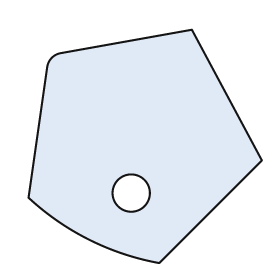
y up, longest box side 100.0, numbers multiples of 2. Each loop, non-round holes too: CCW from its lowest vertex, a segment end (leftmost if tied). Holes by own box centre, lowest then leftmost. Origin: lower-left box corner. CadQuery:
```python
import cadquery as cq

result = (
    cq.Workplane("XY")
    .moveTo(56.0, 0.0)
    .lineTo(100.0, 44.0)
    .lineTo(70.0, 100.0)
    .lineTo(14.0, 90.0)
    .threePointArc((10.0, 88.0), (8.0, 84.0))
    .lineTo(0.0, 28.0)
    .threePointArc((26.0, 10.0), (56.0, 0.0))
    .close()
    .moveTo(44.0, 30.0)
    .circle(8.0)
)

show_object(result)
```